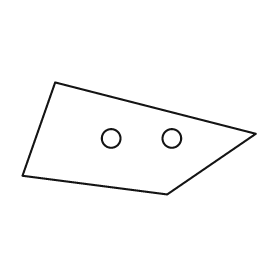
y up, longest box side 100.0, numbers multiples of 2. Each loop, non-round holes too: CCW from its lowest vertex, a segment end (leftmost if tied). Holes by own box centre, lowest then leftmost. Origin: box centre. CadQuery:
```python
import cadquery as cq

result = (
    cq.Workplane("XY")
    .moveTo(12.0, -24.0)
    .lineTo(50.0, 2.0)
    .lineTo(-36.0, 24.0)
    .lineTo(-50.0, -16.0)
    .close()
    .moveTo(-12.0, 0.0)
    .circle(4.0)
    .moveTo(14.0, 0.0)
    .circle(4.0)
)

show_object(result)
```